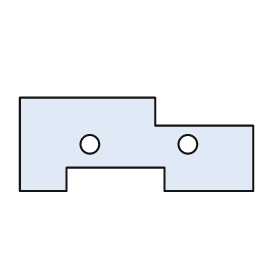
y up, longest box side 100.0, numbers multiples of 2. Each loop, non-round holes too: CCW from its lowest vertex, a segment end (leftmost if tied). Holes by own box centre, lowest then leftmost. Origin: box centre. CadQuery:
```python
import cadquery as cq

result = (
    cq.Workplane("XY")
    .moveTo(-50.0, -20.0)
    .lineTo(-30.0, -20.0)
    .lineTo(-30.0, -10.0)
    .lineTo(12.0, -10.0)
    .lineTo(12.0, -20.0)
    .lineTo(50.0, -20.0)
    .lineTo(50.0, 8.0)
    .lineTo(8.0, 8.0)
    .lineTo(8.0, 20.0)
    .lineTo(-50.0, 20.0)
    .close()
    .moveTo(-20.0, 0.0)
    .circle(4.0)
    .moveTo(22.0, 0.0)
    .circle(4.0)
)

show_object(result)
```